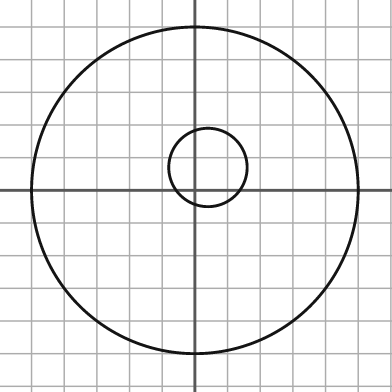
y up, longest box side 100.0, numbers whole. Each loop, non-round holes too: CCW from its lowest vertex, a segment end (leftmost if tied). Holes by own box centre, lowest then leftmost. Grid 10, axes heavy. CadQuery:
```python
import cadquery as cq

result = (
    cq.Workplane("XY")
    .moveTo(0.0, 0.0)
    .circle(50.0)
    .moveTo(4.0, 7.0)
    .circle(12.0)
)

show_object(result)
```